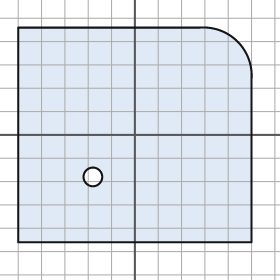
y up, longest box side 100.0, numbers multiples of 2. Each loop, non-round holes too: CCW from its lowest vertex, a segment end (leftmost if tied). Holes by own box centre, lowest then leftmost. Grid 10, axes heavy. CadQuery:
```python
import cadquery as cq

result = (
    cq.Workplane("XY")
    .moveTo(-50.0, -46.0)
    .lineTo(50.0, -46.0)
    .lineTo(50.0, 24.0)
    .threePointArc((44.0, 40.0), (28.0, 46.0))
    .lineTo(-50.0, 46.0)
    .close()
    .moveTo(-18.0, -18.0)
    .circle(4.0)
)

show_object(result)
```